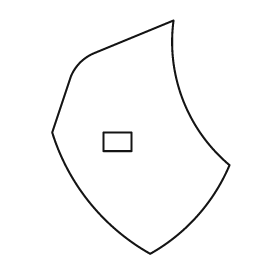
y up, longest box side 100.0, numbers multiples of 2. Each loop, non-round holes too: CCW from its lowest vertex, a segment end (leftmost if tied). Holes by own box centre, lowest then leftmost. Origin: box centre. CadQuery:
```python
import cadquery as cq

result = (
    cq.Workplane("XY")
    .moveTo(4.0, -50.0)
    .threePointArc((24.0, -34.0), (38.0, -12.0))
    .threePointArc((18.0, 16.0), (14.0, 50.0))
    .lineTo(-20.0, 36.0)
    .threePointArc((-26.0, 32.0), (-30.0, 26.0))
    .lineTo(-38.0, 2.0)
    .threePointArc((-22.0, -28.0), (4.0, -50.0))
    .close()
    .moveTo(-16.0, -6.0)
    .lineTo(-4.0, -6.0)
    .lineTo(-4.0, 2.0)
    .lineTo(-16.0, 2.0)
    .close()
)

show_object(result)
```